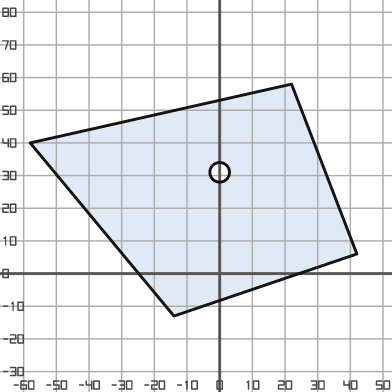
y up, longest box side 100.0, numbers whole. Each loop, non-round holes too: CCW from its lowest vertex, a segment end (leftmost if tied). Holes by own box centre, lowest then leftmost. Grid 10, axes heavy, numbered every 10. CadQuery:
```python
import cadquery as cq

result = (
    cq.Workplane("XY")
    .moveTo(-14.0, -13.0)
    .lineTo(42.0, 6.0)
    .lineTo(22.0, 58.0)
    .lineTo(-58.0, 40.0)
    .close()
    .moveTo(0.0, 31.0)
    .circle(3.0)
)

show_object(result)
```